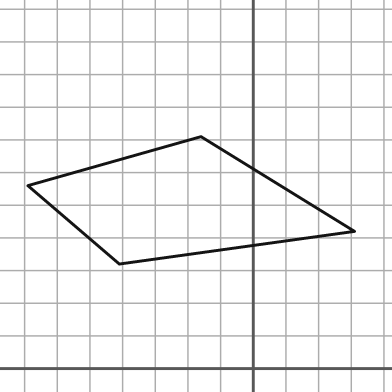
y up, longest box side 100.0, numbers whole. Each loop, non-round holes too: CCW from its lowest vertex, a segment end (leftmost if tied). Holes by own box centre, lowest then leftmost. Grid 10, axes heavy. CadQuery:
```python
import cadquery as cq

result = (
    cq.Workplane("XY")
    .moveTo(-41.0, 32.0)
    .lineTo(31.0, 42.0)
    .lineTo(-16.0, 71.0)
    .lineTo(-69.0, 56.0)
    .close()
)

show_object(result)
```